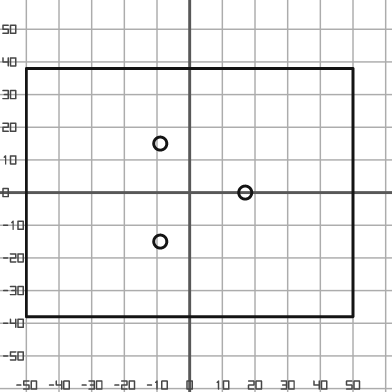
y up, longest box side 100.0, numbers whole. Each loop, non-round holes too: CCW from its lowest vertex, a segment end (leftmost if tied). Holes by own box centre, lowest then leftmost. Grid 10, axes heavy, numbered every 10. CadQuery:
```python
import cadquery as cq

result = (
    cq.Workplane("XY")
    .moveTo(-50.0, -38.0)
    .lineTo(50.0, -38.0)
    .lineTo(50.0, 38.0)
    .lineTo(-50.0, 38.0)
    .close()
    .moveTo(-9.0, -15.0)
    .circle(2.0)
    .moveTo(17.0, 0.0)
    .circle(2.0)
    .moveTo(-9.0, 15.0)
    .circle(2.0)
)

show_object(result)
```